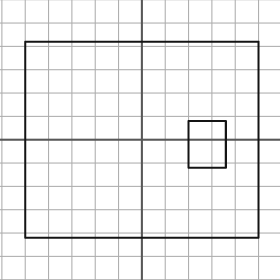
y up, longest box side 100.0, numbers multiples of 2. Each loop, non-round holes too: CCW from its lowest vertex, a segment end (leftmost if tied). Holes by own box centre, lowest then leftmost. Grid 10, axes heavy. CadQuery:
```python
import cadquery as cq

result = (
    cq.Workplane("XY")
    .moveTo(-50.0, -42.0)
    .lineTo(50.0, -42.0)
    .lineTo(50.0, 42.0)
    .lineTo(-50.0, 42.0)
    .close()
    .moveTo(20.0, -12.0)
    .lineTo(36.0, -12.0)
    .lineTo(36.0, 8.0)
    .lineTo(20.0, 8.0)
    .close()
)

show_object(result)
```